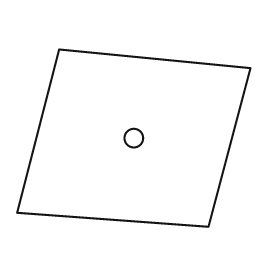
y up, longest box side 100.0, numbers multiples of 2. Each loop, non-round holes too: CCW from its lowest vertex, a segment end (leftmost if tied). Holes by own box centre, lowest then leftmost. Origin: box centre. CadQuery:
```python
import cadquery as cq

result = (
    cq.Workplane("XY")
    .moveTo(32.0, -38.0)
    .lineTo(50.0, 30.0)
    .lineTo(-32.0, 38.0)
    .lineTo(-50.0, -32.0)
    .close()
    .moveTo(0.0, 0.0)
    .circle(4.0)
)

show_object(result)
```